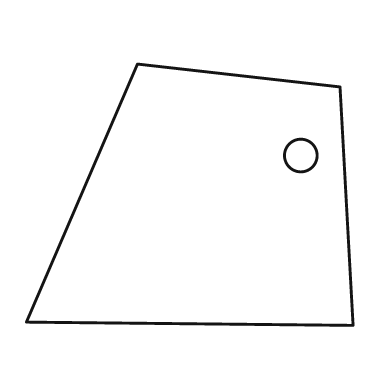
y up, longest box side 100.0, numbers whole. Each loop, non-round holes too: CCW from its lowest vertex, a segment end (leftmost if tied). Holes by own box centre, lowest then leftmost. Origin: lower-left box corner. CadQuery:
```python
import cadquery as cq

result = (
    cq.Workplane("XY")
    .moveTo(100.0, 0.0)
    .lineTo(96.0, 73.0)
    .lineTo(34.0, 80.0)
    .lineTo(0.0, 1.0)
    .close()
    .moveTo(84.0, 52.0)
    .circle(5.0)
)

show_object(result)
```